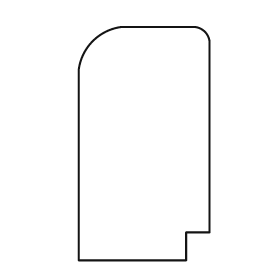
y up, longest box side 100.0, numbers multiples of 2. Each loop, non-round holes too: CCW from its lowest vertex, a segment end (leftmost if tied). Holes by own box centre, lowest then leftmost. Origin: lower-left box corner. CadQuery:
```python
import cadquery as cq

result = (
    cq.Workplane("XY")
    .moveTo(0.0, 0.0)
    .lineTo(46.0, 0.0)
    .lineTo(46.0, 12.0)
    .lineTo(56.0, 12.0)
    .lineTo(56.0, 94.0)
    .threePointArc((54.0, 98.0), (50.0, 100.0))
    .lineTo(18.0, 100.0)
    .threePointArc((6.0, 94.0), (0.0, 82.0))
    .close()
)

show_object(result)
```